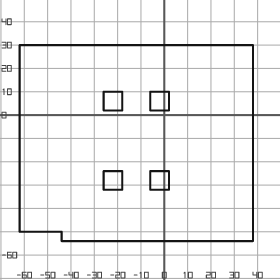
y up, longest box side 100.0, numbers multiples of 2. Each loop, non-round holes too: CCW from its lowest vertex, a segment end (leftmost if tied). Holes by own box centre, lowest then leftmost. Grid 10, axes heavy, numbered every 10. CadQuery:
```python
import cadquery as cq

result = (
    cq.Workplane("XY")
    .moveTo(-44.0, -54.0)
    .lineTo(38.0, -54.0)
    .lineTo(38.0, 30.0)
    .lineTo(-62.0, 30.0)
    .lineTo(-62.0, -50.0)
    .lineTo(-44.0, -50.0)
    .close()
    .moveTo(-26.0, -32.0)
    .lineTo(-18.0, -32.0)
    .lineTo(-18.0, -24.0)
    .lineTo(-26.0, -24.0)
    .close()
    .moveTo(-6.0, -32.0)
    .lineTo(2.0, -32.0)
    .lineTo(2.0, -24.0)
    .lineTo(-6.0, -24.0)
    .close()
    .moveTo(-26.0, 2.0)
    .lineTo(-18.0, 2.0)
    .lineTo(-18.0, 10.0)
    .lineTo(-26.0, 10.0)
    .close()
    .moveTo(-6.0, 2.0)
    .lineTo(2.0, 2.0)
    .lineTo(2.0, 10.0)
    .lineTo(-6.0, 10.0)
    .close()
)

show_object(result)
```